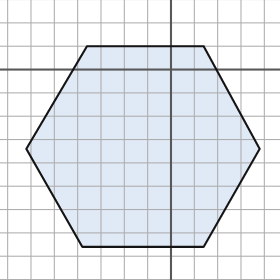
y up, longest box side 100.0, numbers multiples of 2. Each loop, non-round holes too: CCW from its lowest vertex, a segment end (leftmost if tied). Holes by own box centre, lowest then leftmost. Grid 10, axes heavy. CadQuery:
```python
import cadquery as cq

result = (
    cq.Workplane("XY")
    .moveTo(-38.0, -76.0)
    .lineTo(14.0, -76.0)
    .lineTo(38.0, -34.0)
    .lineTo(14.0, 10.0)
    .lineTo(-36.0, 10.0)
    .lineTo(-62.0, -34.0)
    .close()
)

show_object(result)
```